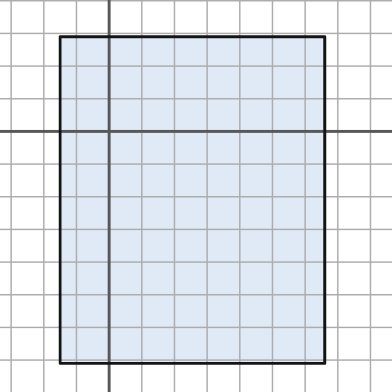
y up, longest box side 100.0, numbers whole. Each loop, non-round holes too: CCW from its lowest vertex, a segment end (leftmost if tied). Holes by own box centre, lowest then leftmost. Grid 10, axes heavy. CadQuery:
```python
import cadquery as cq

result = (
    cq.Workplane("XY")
    .moveTo(-15.0, -71.0)
    .lineTo(66.0, -71.0)
    .lineTo(66.0, 29.0)
    .lineTo(-15.0, 29.0)
    .close()
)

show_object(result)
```